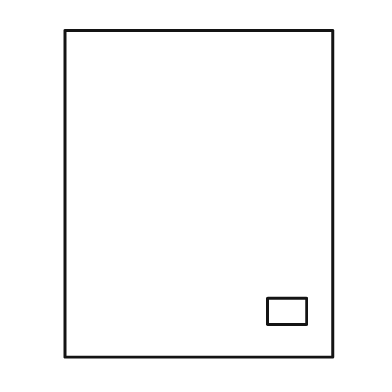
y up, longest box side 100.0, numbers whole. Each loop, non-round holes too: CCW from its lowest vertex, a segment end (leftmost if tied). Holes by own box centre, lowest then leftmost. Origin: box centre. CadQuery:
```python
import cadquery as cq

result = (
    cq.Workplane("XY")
    .moveTo(-41.0, -50.0)
    .lineTo(41.0, -50.0)
    .lineTo(41.0, 50.0)
    .lineTo(-41.0, 50.0)
    .close()
    .moveTo(21.0, -40.0)
    .lineTo(33.0, -40.0)
    .lineTo(33.0, -32.0)
    .lineTo(21.0, -32.0)
    .close()
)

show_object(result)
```